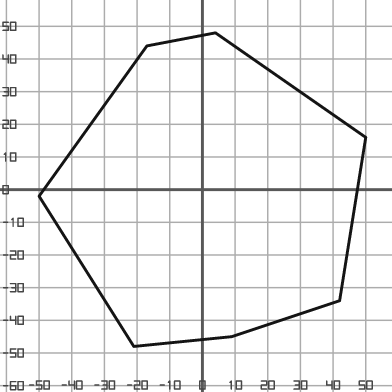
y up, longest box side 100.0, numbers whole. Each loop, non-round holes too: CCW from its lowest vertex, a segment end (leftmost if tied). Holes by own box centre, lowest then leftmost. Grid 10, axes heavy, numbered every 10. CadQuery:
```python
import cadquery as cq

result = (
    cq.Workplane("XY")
    .moveTo(-21.0, -48.0)
    .lineTo(9.0, -45.0)
    .lineTo(42.0, -34.0)
    .lineTo(50.0, 16.0)
    .lineTo(4.0, 48.0)
    .lineTo(-17.0, 44.0)
    .lineTo(-50.0, -2.0)
    .close()
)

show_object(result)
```